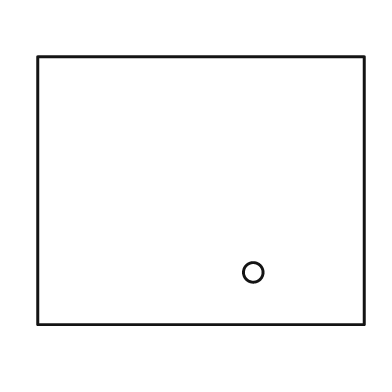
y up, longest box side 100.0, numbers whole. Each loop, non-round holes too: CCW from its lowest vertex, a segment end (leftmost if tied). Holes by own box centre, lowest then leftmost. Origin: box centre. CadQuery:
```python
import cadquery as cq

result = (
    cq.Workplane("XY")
    .moveTo(-50.0, -41.0)
    .lineTo(50.0, -41.0)
    .lineTo(50.0, 41.0)
    .lineTo(-50.0, 41.0)
    .close()
    .moveTo(16.0, -25.0)
    .circle(3.0)
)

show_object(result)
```